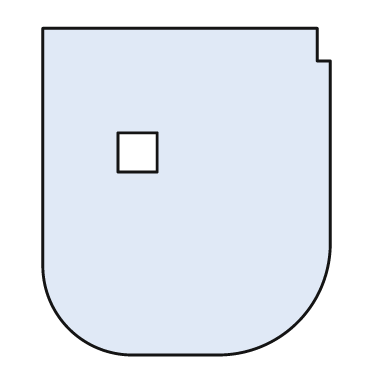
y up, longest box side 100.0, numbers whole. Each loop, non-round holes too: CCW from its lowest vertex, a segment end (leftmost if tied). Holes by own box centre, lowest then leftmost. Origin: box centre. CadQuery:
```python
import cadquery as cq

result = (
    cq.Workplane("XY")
    .moveTo(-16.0, -50.0)
    .lineTo(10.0, -50.0)
    .threePointArc((34.0, -40.0), (44.0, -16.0))
    .lineTo(44.0, 40.0)
    .lineTo(40.0, 40.0)
    .lineTo(40.0, 50.0)
    .lineTo(-44.0, 50.0)
    .lineTo(-44.0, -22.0)
    .threePointArc((-36.0, -42.0), (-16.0, -50.0))
    .close()
    .moveTo(-21.0, 6.0)
    .lineTo(-9.0, 6.0)
    .lineTo(-9.0, 18.0)
    .lineTo(-21.0, 18.0)
    .close()
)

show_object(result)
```